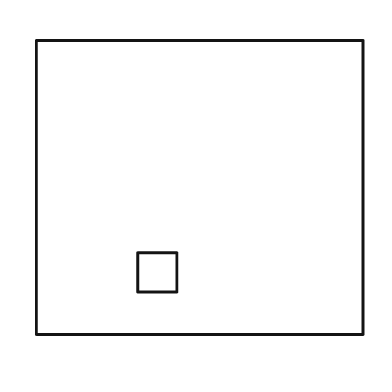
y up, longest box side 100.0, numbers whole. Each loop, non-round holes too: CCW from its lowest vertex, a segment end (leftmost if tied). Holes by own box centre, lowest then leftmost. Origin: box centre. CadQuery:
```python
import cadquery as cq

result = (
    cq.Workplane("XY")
    .moveTo(-50.0, -45.0)
    .lineTo(50.0, -45.0)
    .lineTo(50.0, 45.0)
    .lineTo(-50.0, 45.0)
    .close()
    .moveTo(-19.0, -32.0)
    .lineTo(-7.0, -32.0)
    .lineTo(-7.0, -20.0)
    .lineTo(-19.0, -20.0)
    .close()
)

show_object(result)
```